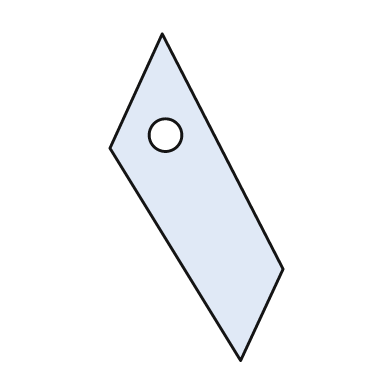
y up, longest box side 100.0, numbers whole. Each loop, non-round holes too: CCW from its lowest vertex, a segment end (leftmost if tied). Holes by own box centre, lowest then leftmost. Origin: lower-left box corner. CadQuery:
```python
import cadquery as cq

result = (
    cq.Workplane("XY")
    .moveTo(40.0, 0.0)
    .lineTo(53.0, 28.0)
    .lineTo(16.0, 100.0)
    .lineTo(0.0, 65.0)
    .close()
    .moveTo(17.0, 69.0)
    .circle(5.0)
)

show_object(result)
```